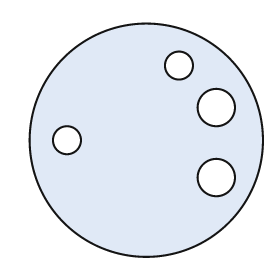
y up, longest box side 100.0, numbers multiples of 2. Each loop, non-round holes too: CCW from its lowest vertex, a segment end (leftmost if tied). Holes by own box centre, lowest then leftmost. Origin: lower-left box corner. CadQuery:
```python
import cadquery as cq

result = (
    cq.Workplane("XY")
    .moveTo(50.0, 50.0)
    .circle(50.0)
    .moveTo(80.0, 34.0)
    .circle(8.0)
    .moveTo(16.0, 50.0)
    .circle(6.0)
    .moveTo(80.0, 64.0)
    .circle(8.0)
    .moveTo(64.0, 82.0)
    .circle(6.0)
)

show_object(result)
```